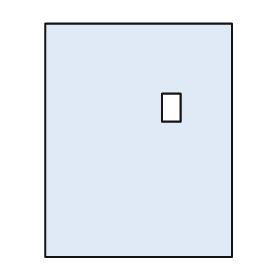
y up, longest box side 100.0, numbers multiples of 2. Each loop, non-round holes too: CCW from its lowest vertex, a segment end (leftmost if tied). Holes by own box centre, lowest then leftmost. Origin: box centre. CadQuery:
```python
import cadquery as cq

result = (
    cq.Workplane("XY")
    .moveTo(-40.0, -50.0)
    .lineTo(40.0, -50.0)
    .lineTo(40.0, 50.0)
    .lineTo(-40.0, 50.0)
    .close()
    .moveTo(10.0, 8.0)
    .lineTo(18.0, 8.0)
    .lineTo(18.0, 20.0)
    .lineTo(10.0, 20.0)
    .close()
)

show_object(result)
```